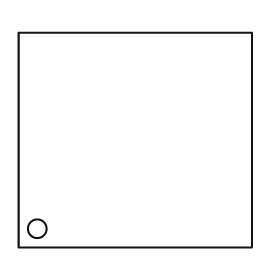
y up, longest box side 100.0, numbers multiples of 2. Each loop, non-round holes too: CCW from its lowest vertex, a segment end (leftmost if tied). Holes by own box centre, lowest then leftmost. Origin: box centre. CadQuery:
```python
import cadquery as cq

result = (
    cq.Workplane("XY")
    .moveTo(-50.0, -46.0)
    .lineTo(50.0, -46.0)
    .lineTo(50.0, 46.0)
    .lineTo(-50.0, 46.0)
    .close()
    .moveTo(-42.0, -38.0)
    .circle(4.0)
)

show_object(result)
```